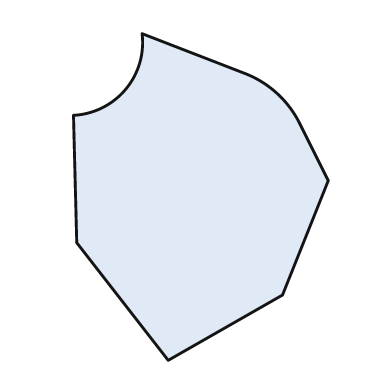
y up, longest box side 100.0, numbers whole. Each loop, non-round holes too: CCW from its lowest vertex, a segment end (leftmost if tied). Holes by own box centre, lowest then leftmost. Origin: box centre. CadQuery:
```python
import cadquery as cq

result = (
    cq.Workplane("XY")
    .moveTo(-10.0, -50.0)
    .lineTo(25.0, -30.0)
    .lineTo(39.0, 5.0)
    .lineTo(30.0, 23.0)
    .threePointArc((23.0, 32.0), (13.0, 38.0))
    .lineTo(-18.0, 50.0)
    .threePointArc((-23.0, 33.0), (-39.0, 25.0))
    .lineTo(-38.0, -14.0)
    .close()
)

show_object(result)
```